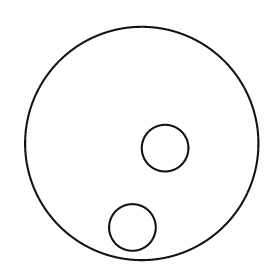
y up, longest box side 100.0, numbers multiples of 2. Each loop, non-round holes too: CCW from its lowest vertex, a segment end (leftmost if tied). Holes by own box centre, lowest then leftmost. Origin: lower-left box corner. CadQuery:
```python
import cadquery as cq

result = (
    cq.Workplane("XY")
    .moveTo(50.0, 50.0)
    .circle(50.0)
    .moveTo(46.0, 14.0)
    .circle(10.0)
    .moveTo(60.0, 48.0)
    .circle(10.0)
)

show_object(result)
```